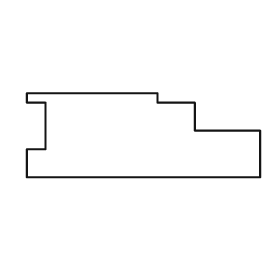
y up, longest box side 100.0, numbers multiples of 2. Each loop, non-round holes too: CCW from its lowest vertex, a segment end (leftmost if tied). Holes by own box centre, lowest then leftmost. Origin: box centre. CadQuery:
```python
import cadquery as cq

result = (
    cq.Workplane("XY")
    .moveTo(-50.0, -18.0)
    .lineTo(50.0, -18.0)
    .lineTo(50.0, 2.0)
    .lineTo(22.0, 2.0)
    .lineTo(22.0, 14.0)
    .lineTo(6.0, 14.0)
    .lineTo(6.0, 18.0)
    .lineTo(-50.0, 18.0)
    .lineTo(-50.0, 14.0)
    .lineTo(-42.0, 14.0)
    .lineTo(-42.0, -6.0)
    .lineTo(-50.0, -6.0)
    .close()
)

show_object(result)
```